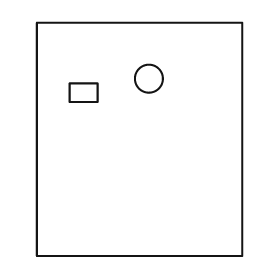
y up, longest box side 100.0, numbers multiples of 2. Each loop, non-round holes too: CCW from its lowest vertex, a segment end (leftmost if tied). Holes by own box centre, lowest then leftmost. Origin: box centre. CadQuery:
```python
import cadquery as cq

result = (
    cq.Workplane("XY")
    .moveTo(-44.0, -50.0)
    .lineTo(44.0, -50.0)
    .lineTo(44.0, 50.0)
    .lineTo(-44.0, 50.0)
    .close()
    .moveTo(-30.0, 16.0)
    .lineTo(-18.0, 16.0)
    .lineTo(-18.0, 24.0)
    .lineTo(-30.0, 24.0)
    .close()
    .moveTo(4.0, 26.0)
    .circle(6.0)
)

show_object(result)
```